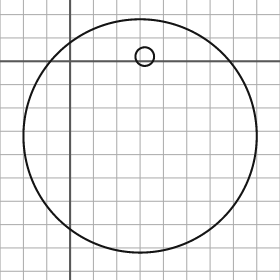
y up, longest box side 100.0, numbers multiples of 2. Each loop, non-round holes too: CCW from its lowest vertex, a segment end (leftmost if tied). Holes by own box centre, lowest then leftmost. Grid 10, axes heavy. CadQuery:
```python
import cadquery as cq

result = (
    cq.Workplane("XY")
    .moveTo(30.0, -32.0)
    .circle(50.0)
    .moveTo(32.0, 2.0)
    .circle(4.0)
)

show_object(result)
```